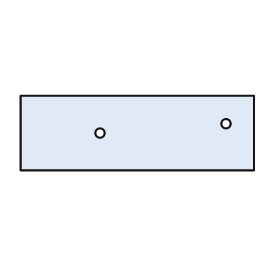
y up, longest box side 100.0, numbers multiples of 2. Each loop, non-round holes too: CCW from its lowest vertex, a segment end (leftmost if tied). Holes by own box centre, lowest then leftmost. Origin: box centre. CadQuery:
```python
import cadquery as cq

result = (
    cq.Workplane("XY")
    .moveTo(-50.0, -16.0)
    .lineTo(50.0, -16.0)
    .lineTo(50.0, 16.0)
    .lineTo(-50.0, 16.0)
    .close()
    .moveTo(-16.0, 0.0)
    .circle(2.0)
    .moveTo(38.0, 4.0)
    .circle(2.0)
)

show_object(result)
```